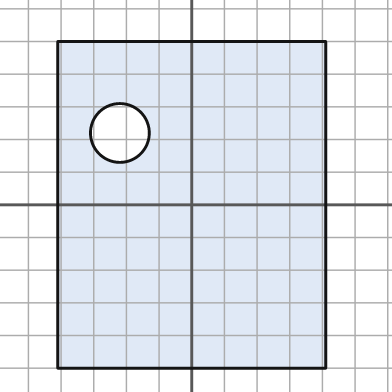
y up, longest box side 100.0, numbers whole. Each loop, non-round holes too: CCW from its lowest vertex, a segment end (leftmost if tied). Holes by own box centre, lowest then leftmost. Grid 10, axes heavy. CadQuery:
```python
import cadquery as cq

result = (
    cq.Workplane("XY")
    .moveTo(-41.0, -50.0)
    .lineTo(41.0, -50.0)
    .lineTo(41.0, 50.0)
    .lineTo(-41.0, 50.0)
    .close()
    .moveTo(-22.0, 22.0)
    .circle(9.0)
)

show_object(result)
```